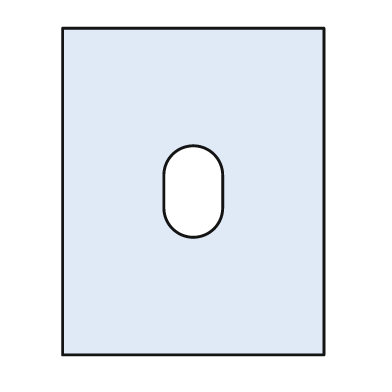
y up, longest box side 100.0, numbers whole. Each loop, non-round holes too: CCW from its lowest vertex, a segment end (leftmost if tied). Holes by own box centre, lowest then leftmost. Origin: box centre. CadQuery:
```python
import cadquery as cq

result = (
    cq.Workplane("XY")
    .moveTo(-40.0, -50.0)
    .lineTo(40.0, -50.0)
    .lineTo(40.0, 50.0)
    .lineTo(-40.0, 50.0)
    .close()
    .moveTo(-9.0, -5.0)
    .threePointArc((0.0, -14.0), (9.0, -5.0))
    .lineTo(9.0, 5.0)
    .threePointArc((0.0, 14.0), (-9.0, 5.0))
    .close()
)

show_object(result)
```